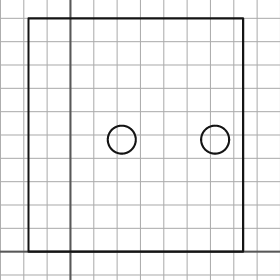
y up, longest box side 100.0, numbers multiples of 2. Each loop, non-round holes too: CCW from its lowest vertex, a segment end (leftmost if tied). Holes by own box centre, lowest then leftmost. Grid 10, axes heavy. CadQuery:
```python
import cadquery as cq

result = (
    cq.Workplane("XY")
    .moveTo(-18.0, 0.0)
    .lineTo(74.0, 0.0)
    .lineTo(74.0, 100.0)
    .lineTo(-18.0, 100.0)
    .close()
    .moveTo(22.0, 48.0)
    .circle(6.0)
    .moveTo(62.0, 48.0)
    .circle(6.0)
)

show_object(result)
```